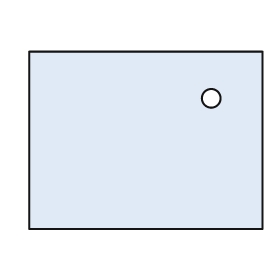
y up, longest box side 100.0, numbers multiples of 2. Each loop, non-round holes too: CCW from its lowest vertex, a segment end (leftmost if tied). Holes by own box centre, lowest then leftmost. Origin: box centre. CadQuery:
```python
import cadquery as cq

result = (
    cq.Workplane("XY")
    .moveTo(-50.0, -38.0)
    .lineTo(50.0, -38.0)
    .lineTo(50.0, 38.0)
    .lineTo(-50.0, 38.0)
    .close()
    .moveTo(28.0, 18.0)
    .circle(4.0)
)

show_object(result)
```